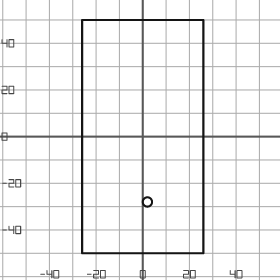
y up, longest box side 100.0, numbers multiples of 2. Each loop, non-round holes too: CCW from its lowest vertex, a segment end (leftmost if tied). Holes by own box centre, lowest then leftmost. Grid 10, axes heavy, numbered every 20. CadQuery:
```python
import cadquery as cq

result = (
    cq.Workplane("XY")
    .moveTo(-26.0, -50.0)
    .lineTo(26.0, -50.0)
    .lineTo(26.0, 50.0)
    .lineTo(-26.0, 50.0)
    .close()
    .moveTo(2.0, -28.0)
    .circle(2.0)
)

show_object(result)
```